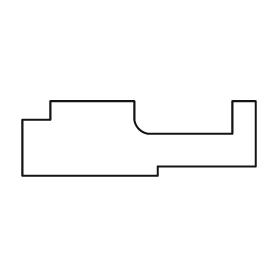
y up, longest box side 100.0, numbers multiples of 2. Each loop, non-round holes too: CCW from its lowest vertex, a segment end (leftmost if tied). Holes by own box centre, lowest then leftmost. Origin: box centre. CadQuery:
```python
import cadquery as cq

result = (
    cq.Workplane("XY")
    .moveTo(-50.0, -16.0)
    .lineTo(8.0, -16.0)
    .lineTo(8.0, -12.0)
    .lineTo(50.0, -12.0)
    .lineTo(50.0, 16.0)
    .lineTo(40.0, 16.0)
    .lineTo(40.0, 2.0)
    .lineTo(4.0, 2.0)
    .threePointArc((0.0, 4.0), (-2.0, 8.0))
    .lineTo(-2.0, 16.0)
    .lineTo(-38.0, 16.0)
    .lineTo(-38.0, 8.0)
    .lineTo(-50.0, 8.0)
    .close()
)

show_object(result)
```